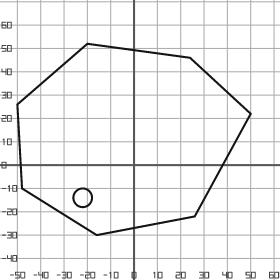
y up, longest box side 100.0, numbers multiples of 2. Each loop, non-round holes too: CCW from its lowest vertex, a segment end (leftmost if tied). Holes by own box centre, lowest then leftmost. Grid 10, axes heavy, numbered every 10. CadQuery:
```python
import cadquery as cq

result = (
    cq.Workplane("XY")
    .moveTo(-16.0, -30.0)
    .lineTo(26.0, -22.0)
    .lineTo(50.0, 22.0)
    .lineTo(24.0, 46.0)
    .lineTo(-20.0, 52.0)
    .lineTo(-50.0, 26.0)
    .lineTo(-48.0, -10.0)
    .close()
    .moveTo(-22.0, -14.0)
    .circle(4.0)
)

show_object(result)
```